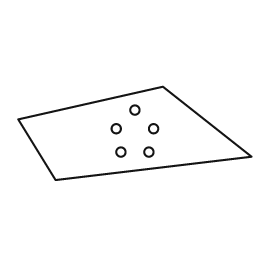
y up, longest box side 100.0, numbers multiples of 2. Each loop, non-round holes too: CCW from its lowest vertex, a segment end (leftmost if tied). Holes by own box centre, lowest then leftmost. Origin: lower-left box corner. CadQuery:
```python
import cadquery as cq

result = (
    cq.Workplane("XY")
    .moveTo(16.0, 0.0)
    .lineTo(100.0, 10.0)
    .lineTo(62.0, 40.0)
    .lineTo(0.0, 26.0)
    .close()
    .moveTo(44.0, 12.0)
    .circle(2.0)
    .moveTo(56.0, 12.0)
    .circle(2.0)
    .moveTo(42.0, 22.0)
    .circle(2.0)
    .moveTo(58.0, 22.0)
    .circle(2.0)
    .moveTo(50.0, 30.0)
    .circle(2.0)
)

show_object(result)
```